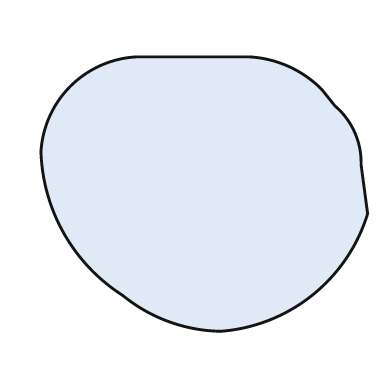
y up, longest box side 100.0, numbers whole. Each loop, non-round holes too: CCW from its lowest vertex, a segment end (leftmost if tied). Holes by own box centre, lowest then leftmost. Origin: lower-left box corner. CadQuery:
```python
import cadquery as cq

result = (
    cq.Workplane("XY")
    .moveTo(55.0, 0.0)
    .threePointArc((83.0, 11.0), (100.0, 36.0))
    .lineTo(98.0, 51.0)
    .threePointArc((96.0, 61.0), (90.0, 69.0))
    .lineTo(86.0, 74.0)
    .threePointArc((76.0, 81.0), (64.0, 84.0))
    .lineTo(29.0, 84.0)
    .threePointArc((9.0, 75.0), (0.0, 55.0))
    .threePointArc((7.0, 30.0), (25.0, 11.0))
    .threePointArc((39.0, 3.0), (55.0, 0.0))
    .close()
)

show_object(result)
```